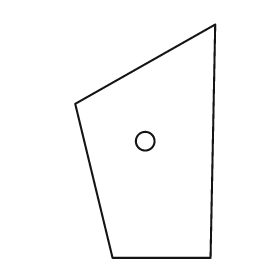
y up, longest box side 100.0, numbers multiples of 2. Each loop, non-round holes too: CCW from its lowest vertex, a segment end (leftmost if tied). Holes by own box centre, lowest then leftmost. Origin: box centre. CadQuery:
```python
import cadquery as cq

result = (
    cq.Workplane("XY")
    .moveTo(-14.0, -50.0)
    .lineTo(28.0, -50.0)
    .lineTo(30.0, 50.0)
    .lineTo(-30.0, 16.0)
    .close()
    .moveTo(0.0, 0.0)
    .circle(4.0)
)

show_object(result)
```